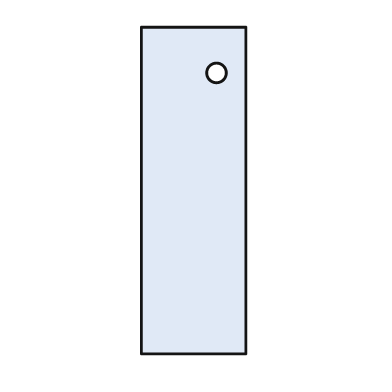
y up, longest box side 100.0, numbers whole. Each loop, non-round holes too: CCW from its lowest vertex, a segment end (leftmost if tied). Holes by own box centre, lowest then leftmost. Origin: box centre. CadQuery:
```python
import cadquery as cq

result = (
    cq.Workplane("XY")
    .moveTo(-16.0, -50.0)
    .lineTo(16.0, -50.0)
    .lineTo(16.0, 50.0)
    .lineTo(-16.0, 50.0)
    .close()
    .moveTo(7.0, 36.0)
    .circle(3.0)
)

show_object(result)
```